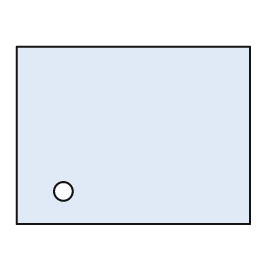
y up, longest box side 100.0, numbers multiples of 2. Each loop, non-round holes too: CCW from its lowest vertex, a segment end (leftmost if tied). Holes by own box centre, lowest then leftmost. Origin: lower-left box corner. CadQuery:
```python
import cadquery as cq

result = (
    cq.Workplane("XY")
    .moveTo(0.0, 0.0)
    .lineTo(100.0, 0.0)
    .lineTo(100.0, 76.0)
    .lineTo(0.0, 76.0)
    .close()
    .moveTo(20.0, 14.0)
    .circle(4.0)
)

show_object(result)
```